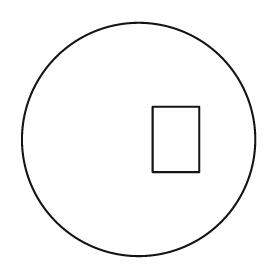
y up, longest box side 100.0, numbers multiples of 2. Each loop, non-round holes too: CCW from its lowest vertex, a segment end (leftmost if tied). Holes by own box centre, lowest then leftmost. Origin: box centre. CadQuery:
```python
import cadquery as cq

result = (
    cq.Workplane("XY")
    .moveTo(0.0, 0.0)
    .circle(50.0)
    .moveTo(6.0, -14.0)
    .lineTo(26.0, -14.0)
    .lineTo(26.0, 14.0)
    .lineTo(6.0, 14.0)
    .close()
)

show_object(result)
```